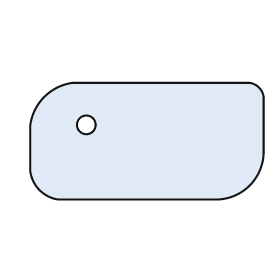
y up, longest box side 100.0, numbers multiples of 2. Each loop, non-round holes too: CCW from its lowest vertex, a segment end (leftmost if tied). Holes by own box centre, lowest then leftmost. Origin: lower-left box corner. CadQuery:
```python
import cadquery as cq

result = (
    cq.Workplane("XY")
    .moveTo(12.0, 0.0)
    .lineTo(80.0, 0.0)
    .threePointArc((94.0, 6.0), (100.0, 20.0))
    .lineTo(100.0, 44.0)
    .threePointArc((98.0, 48.0), (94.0, 50.0))
    .lineTo(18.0, 50.0)
    .threePointArc((6.0, 44.0), (0.0, 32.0))
    .lineTo(0.0, 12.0)
    .threePointArc((4.0, 4.0), (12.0, 0.0))
    .close()
    .moveTo(24.0, 32.0)
    .circle(4.0)
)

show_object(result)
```